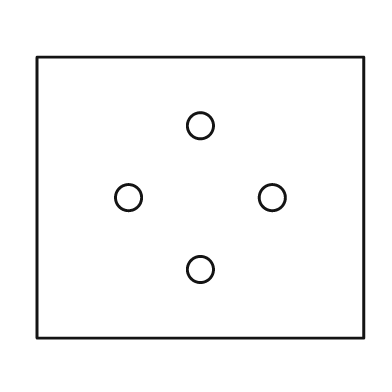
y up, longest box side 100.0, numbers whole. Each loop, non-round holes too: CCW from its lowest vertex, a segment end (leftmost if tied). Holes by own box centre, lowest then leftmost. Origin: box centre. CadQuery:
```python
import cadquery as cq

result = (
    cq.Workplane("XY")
    .moveTo(-50.0, -43.0)
    .lineTo(50.0, -43.0)
    .lineTo(50.0, 43.0)
    .lineTo(-50.0, 43.0)
    .close()
    .moveTo(0.0, -22.0)
    .circle(4.0)
    .moveTo(-22.0, 0.0)
    .circle(4.0)
    .moveTo(22.0, 0.0)
    .circle(4.0)
    .moveTo(0.0, 22.0)
    .circle(4.0)
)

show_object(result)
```